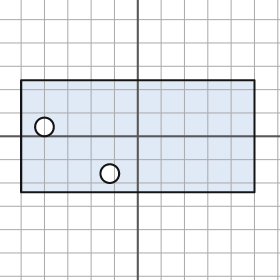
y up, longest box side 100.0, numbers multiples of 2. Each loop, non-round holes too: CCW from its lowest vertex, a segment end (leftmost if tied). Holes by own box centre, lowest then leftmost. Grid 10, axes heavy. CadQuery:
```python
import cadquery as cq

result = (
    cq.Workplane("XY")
    .moveTo(-50.0, -24.0)
    .lineTo(50.0, -24.0)
    .lineTo(50.0, 24.0)
    .lineTo(-50.0, 24.0)
    .close()
    .moveTo(-12.0, -16.0)
    .circle(4.0)
    .moveTo(-40.0, 4.0)
    .circle(4.0)
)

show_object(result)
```